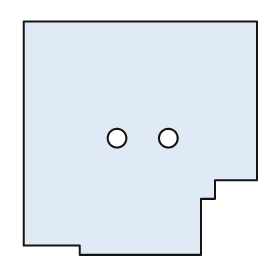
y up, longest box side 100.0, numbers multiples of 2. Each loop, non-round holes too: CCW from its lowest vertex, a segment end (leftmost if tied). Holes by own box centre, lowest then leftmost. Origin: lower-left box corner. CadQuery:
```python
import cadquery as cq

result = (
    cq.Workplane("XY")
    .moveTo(24.0, 0.0)
    .lineTo(76.0, 0.0)
    .lineTo(76.0, 24.0)
    .lineTo(82.0, 24.0)
    .lineTo(82.0, 32.0)
    .lineTo(100.0, 32.0)
    .lineTo(100.0, 100.0)
    .lineTo(0.0, 100.0)
    .lineTo(0.0, 4.0)
    .lineTo(24.0, 4.0)
    .close()
    .moveTo(40.0, 50.0)
    .circle(4.0)
    .moveTo(62.0, 50.0)
    .circle(4.0)
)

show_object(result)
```